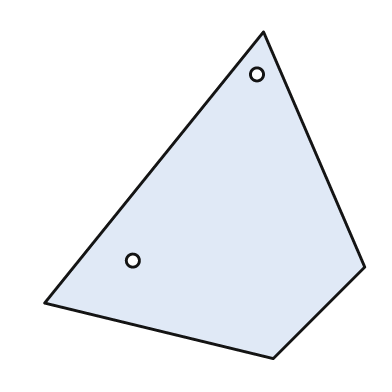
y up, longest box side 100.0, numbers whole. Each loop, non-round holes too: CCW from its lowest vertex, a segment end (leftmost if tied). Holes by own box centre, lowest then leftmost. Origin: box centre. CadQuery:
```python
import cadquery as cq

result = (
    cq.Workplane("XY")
    .moveTo(21.0, -50.0)
    .lineTo(49.0, -22.0)
    .lineTo(18.0, 50.0)
    .lineTo(-49.0, -33.0)
    .close()
    .moveTo(-22.0, -20.0)
    .circle(2.0)
    .moveTo(16.0, 37.0)
    .circle(2.0)
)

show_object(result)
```